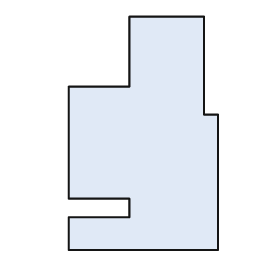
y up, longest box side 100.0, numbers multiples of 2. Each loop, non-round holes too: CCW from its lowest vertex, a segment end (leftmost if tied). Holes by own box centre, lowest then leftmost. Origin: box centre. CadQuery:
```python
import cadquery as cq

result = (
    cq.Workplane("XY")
    .moveTo(-32.0, -50.0)
    .lineTo(32.0, -50.0)
    .lineTo(32.0, 8.0)
    .lineTo(26.0, 8.0)
    .lineTo(26.0, 50.0)
    .lineTo(-6.0, 50.0)
    .lineTo(-6.0, 20.0)
    .lineTo(-32.0, 20.0)
    .lineTo(-32.0, -28.0)
    .lineTo(-6.0, -28.0)
    .lineTo(-6.0, -36.0)
    .lineTo(-32.0, -36.0)
    .close()
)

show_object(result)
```